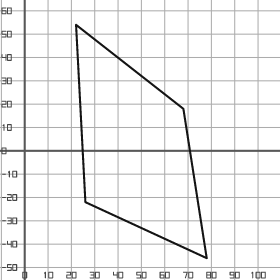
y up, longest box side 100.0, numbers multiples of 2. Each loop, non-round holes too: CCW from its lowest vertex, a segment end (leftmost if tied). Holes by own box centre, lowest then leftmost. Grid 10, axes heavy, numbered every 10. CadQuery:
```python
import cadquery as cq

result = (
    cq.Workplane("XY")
    .moveTo(78.0, -46.0)
    .lineTo(68.0, 18.0)
    .lineTo(22.0, 54.0)
    .lineTo(26.0, -22.0)
    .close()
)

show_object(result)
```